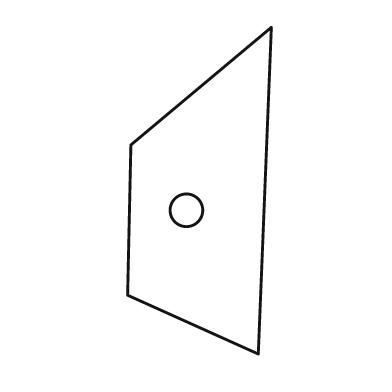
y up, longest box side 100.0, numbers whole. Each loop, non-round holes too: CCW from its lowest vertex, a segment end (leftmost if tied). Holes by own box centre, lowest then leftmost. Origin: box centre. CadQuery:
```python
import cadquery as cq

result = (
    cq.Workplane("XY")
    .moveTo(18.0, -50.0)
    .lineTo(22.0, 50.0)
    .lineTo(-21.0, 14.0)
    .lineTo(-22.0, -32.0)
    .close()
    .moveTo(-4.0, -6.0)
    .circle(5.0)
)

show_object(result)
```